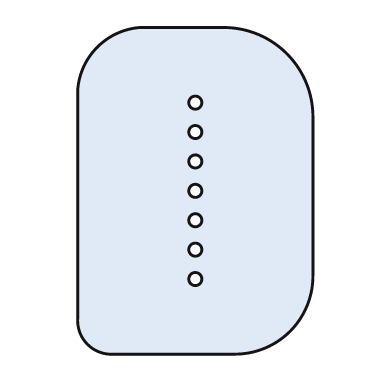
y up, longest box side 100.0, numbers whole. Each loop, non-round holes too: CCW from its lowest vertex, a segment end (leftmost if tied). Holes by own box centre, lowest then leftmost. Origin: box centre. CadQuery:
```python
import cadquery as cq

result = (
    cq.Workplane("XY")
    .moveTo(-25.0, -50.0)
    .lineTo(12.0, -50.0)
    .threePointArc((29.0, -43.0), (36.0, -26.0))
    .lineTo(36.0, 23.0)
    .threePointArc((28.0, 42.0), (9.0, 50.0))
    .lineTo(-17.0, 50.0)
    .threePointArc((-30.0, 44.0), (-36.0, 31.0))
    .lineTo(-36.0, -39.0)
    .threePointArc((-33.0, -47.0), (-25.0, -50.0))
    .close()
    .moveTo(0.0, -27.0)
    .circle(2.0)
    .moveTo(0.0, -18.0)
    .circle(2.0)
    .moveTo(0.0, -9.0)
    .circle(2.0)
    .moveTo(0.0, 0.0)
    .circle(2.0)
    .moveTo(0.0, 9.0)
    .circle(2.0)
    .moveTo(0.0, 18.0)
    .circle(2.0)
    .moveTo(0.0, 27.0)
    .circle(2.0)
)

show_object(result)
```